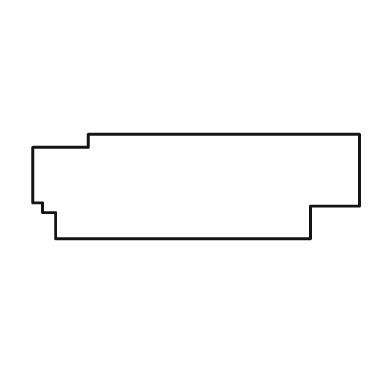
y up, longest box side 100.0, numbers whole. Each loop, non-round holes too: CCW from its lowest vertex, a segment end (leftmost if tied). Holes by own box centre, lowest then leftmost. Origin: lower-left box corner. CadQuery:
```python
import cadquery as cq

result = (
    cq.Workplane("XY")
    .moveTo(7.0, 0.0)
    .lineTo(85.0, 0.0)
    .lineTo(85.0, 10.0)
    .lineTo(100.0, 10.0)
    .lineTo(100.0, 32.0)
    .lineTo(17.0, 32.0)
    .lineTo(17.0, 28.0)
    .lineTo(0.0, 28.0)
    .lineTo(0.0, 11.0)
    .lineTo(3.0, 11.0)
    .lineTo(3.0, 8.0)
    .lineTo(7.0, 8.0)
    .close()
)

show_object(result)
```